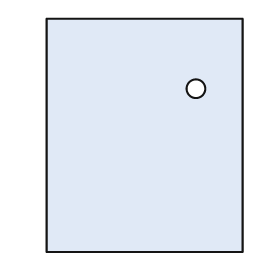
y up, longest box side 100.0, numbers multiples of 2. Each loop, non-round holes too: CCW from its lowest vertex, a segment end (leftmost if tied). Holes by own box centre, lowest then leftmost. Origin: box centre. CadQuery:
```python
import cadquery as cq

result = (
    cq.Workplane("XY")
    .moveTo(-42.0, -50.0)
    .lineTo(42.0, -50.0)
    .lineTo(42.0, 50.0)
    .lineTo(-42.0, 50.0)
    .close()
    .moveTo(22.0, 20.0)
    .circle(4.0)
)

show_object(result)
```